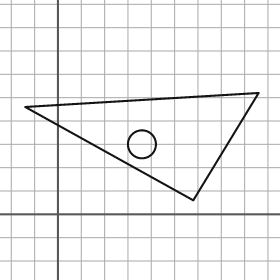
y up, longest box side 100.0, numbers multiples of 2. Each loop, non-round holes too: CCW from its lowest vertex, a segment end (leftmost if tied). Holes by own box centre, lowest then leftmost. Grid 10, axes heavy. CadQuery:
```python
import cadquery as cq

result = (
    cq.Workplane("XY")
    .moveTo(58.0, 6.0)
    .lineTo(86.0, 52.0)
    .lineTo(-14.0, 46.0)
    .close()
    .moveTo(36.0, 30.0)
    .circle(6.0)
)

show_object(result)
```